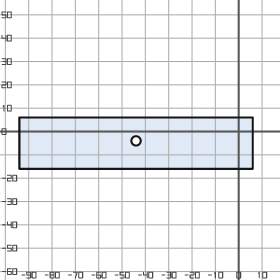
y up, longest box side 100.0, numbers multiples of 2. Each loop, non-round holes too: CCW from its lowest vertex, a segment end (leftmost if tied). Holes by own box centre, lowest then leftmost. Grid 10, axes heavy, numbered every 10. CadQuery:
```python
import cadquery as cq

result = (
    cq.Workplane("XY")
    .moveTo(-94.0, -16.0)
    .lineTo(6.0, -16.0)
    .lineTo(6.0, 6.0)
    .lineTo(-94.0, 6.0)
    .close()
    .moveTo(-44.0, -4.0)
    .circle(2.0)
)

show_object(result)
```